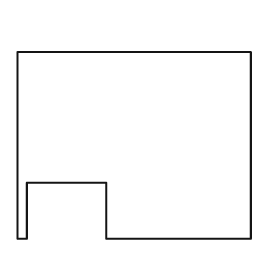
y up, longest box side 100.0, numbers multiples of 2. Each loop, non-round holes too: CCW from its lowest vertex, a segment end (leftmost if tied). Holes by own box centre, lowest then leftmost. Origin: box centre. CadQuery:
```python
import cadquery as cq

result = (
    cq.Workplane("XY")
    .moveTo(-50.0, -40.0)
    .lineTo(-46.0, -40.0)
    .lineTo(-46.0, -16.0)
    .lineTo(-12.0, -16.0)
    .lineTo(-12.0, -40.0)
    .lineTo(50.0, -40.0)
    .lineTo(50.0, 40.0)
    .lineTo(-50.0, 40.0)
    .close()
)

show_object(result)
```